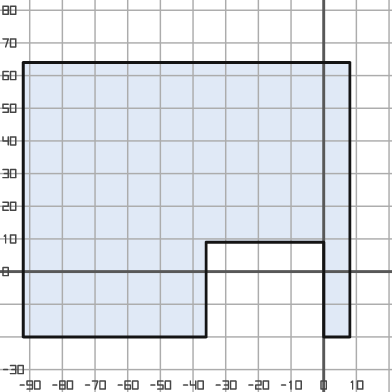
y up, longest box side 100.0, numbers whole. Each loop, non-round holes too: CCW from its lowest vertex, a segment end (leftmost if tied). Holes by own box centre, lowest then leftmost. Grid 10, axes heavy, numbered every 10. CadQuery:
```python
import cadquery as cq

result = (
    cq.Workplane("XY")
    .moveTo(-92.0, -20.0)
    .lineTo(-36.0, -20.0)
    .lineTo(-36.0, 9.0)
    .lineTo(0.0, 9.0)
    .lineTo(0.0, -20.0)
    .lineTo(8.0, -20.0)
    .lineTo(8.0, 64.0)
    .lineTo(-92.0, 64.0)
    .close()
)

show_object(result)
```